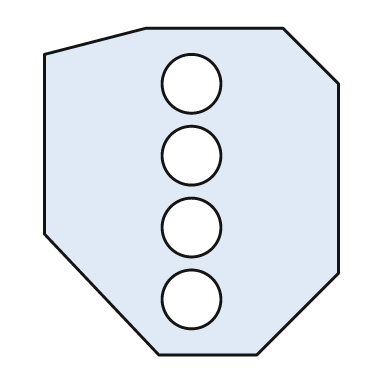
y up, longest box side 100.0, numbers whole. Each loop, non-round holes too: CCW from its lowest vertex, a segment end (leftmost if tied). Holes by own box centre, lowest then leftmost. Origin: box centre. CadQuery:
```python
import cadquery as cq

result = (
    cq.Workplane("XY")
    .moveTo(-10.0, -50.0)
    .lineTo(20.0, -50.0)
    .lineTo(45.0, -25.0)
    .lineTo(45.0, 33.0)
    .lineTo(28.0, 50.0)
    .lineTo(-14.0, 50.0)
    .lineTo(-45.0, 42.0)
    .lineTo(-45.0, -13.0)
    .close()
    .moveTo(0.0, -33.0)
    .circle(9.0)
    .moveTo(0.0, -11.0)
    .circle(9.0)
    .moveTo(0.0, 11.0)
    .circle(9.0)
    .moveTo(0.0, 33.0)
    .circle(9.0)
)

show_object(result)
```